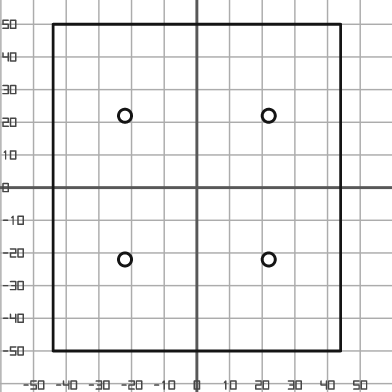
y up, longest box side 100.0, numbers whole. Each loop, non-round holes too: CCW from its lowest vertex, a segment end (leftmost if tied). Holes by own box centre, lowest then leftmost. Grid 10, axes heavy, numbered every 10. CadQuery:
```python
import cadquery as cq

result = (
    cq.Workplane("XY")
    .moveTo(-44.0, -50.0)
    .lineTo(44.0, -50.0)
    .lineTo(44.0, 50.0)
    .lineTo(-44.0, 50.0)
    .close()
    .moveTo(-22.0, -22.0)
    .circle(2.0)
    .moveTo(22.0, -22.0)
    .circle(2.0)
    .moveTo(-22.0, 22.0)
    .circle(2.0)
    .moveTo(22.0, 22.0)
    .circle(2.0)
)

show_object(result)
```